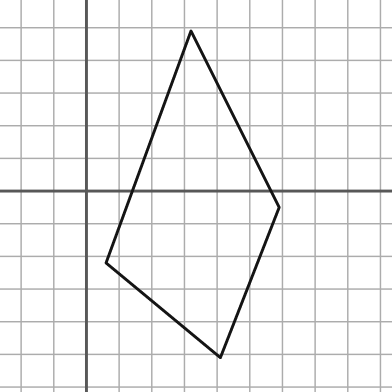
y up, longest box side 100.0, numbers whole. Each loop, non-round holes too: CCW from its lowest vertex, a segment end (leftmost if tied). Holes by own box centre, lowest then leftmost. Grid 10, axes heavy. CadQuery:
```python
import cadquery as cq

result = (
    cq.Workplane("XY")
    .moveTo(41.0, -51.0)
    .lineTo(59.0, -5.0)
    .lineTo(32.0, 49.0)
    .lineTo(6.0, -22.0)
    .close()
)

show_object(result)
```